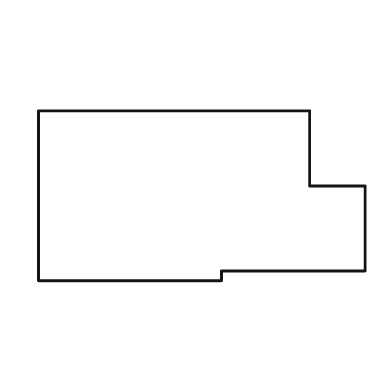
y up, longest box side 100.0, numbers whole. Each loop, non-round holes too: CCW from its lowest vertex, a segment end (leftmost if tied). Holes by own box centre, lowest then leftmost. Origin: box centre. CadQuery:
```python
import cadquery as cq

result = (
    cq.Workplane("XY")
    .moveTo(-50.0, -26.0)
    .lineTo(6.0, -26.0)
    .lineTo(6.0, -23.0)
    .lineTo(50.0, -23.0)
    .lineTo(50.0, 3.0)
    .lineTo(33.0, 3.0)
    .lineTo(33.0, 26.0)
    .lineTo(-50.0, 26.0)
    .close()
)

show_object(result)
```